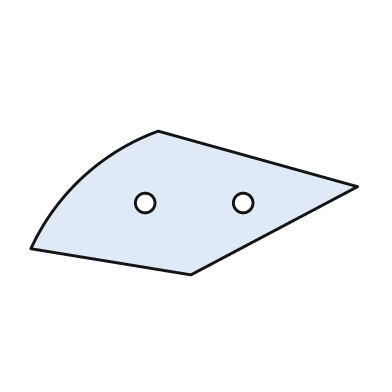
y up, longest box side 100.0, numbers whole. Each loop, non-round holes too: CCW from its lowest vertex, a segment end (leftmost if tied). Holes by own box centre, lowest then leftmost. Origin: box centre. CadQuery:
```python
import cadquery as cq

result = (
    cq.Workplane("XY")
    .moveTo(-1.0, -22.0)
    .lineTo(50.0, 5.0)
    .lineTo(-11.0, 22.0)
    .threePointArc((-34.0, 8.0), (-50.0, -14.0))
    .close()
    .moveTo(-15.0, 0.0)
    .circle(3.0)
    .moveTo(15.0, 0.0)
    .circle(3.0)
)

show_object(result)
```